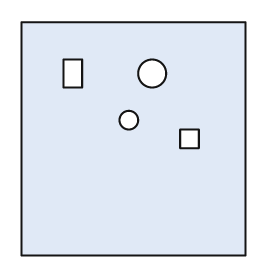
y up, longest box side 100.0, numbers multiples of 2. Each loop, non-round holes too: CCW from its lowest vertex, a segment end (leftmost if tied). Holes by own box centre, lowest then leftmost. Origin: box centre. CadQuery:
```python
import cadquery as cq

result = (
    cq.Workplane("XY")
    .moveTo(-48.0, -50.0)
    .lineTo(48.0, -50.0)
    .lineTo(48.0, 50.0)
    .lineTo(-48.0, 50.0)
    .close()
    .moveTo(20.0, -4.0)
    .lineTo(28.0, -4.0)
    .lineTo(28.0, 4.0)
    .lineTo(20.0, 4.0)
    .close()
    .moveTo(-2.0, 8.0)
    .circle(4.0)
    .moveTo(-30.0, 22.0)
    .lineTo(-22.0, 22.0)
    .lineTo(-22.0, 34.0)
    .lineTo(-30.0, 34.0)
    .close()
    .moveTo(8.0, 28.0)
    .circle(6.0)
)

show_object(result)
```